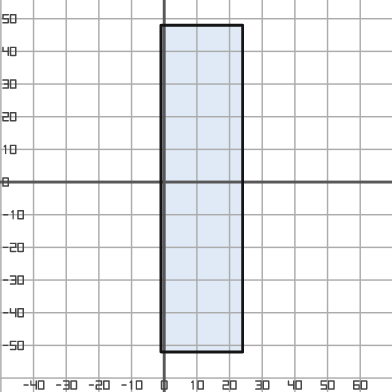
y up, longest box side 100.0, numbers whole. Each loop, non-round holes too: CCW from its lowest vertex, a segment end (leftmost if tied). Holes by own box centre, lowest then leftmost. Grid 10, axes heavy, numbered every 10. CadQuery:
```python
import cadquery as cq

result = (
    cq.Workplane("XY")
    .moveTo(-1.0, -52.0)
    .lineTo(24.0, -52.0)
    .lineTo(24.0, 48.0)
    .lineTo(-1.0, 48.0)
    .close()
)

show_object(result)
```